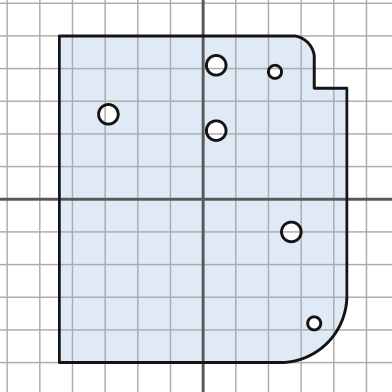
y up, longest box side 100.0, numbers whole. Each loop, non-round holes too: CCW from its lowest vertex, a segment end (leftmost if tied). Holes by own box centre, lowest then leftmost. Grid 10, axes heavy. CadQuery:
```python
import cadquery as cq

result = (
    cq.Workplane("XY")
    .moveTo(-44.0, -50.0)
    .lineTo(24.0, -50.0)
    .threePointArc((38.0, -44.0), (44.0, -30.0))
    .lineTo(44.0, 34.0)
    .lineTo(34.0, 34.0)
    .lineTo(34.0, 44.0)
    .threePointArc((32.0, 48.0), (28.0, 50.0))
    .lineTo(-44.0, 50.0)
    .close()
    .moveTo(34.0, -38.0)
    .circle(2.0)
    .moveTo(27.0, -10.0)
    .circle(3.0)
    .moveTo(4.0, 21.0)
    .circle(3.0)
    .moveTo(-29.0, 26.0)
    .circle(3.0)
    .moveTo(22.0, 39.0)
    .circle(2.0)
    .moveTo(4.0, 41.0)
    .circle(3.0)
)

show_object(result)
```